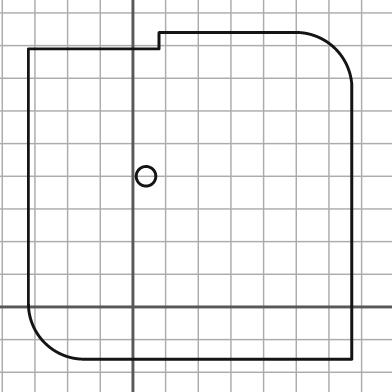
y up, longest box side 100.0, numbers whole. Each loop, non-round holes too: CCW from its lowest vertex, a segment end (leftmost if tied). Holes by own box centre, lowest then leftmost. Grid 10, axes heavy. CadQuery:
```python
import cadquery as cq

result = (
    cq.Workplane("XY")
    .moveTo(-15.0, -16.0)
    .lineTo(67.0, -16.0)
    .lineTo(67.0, 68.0)
    .threePointArc((62.0, 79.0), (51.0, 84.0))
    .lineTo(8.0, 84.0)
    .lineTo(8.0, 79.0)
    .lineTo(-32.0, 79.0)
    .lineTo(-32.0, 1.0)
    .threePointArc((-27.0, -11.0), (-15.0, -16.0))
    .close()
    .moveTo(4.0, 40.0)
    .circle(3.0)
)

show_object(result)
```